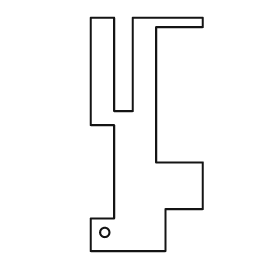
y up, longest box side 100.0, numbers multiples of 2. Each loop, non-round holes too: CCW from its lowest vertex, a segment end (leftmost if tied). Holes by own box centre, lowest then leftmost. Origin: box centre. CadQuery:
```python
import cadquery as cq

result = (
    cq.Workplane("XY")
    .moveTo(-24.0, -50.0)
    .lineTo(8.0, -50.0)
    .lineTo(8.0, -32.0)
    .lineTo(24.0, -32.0)
    .lineTo(24.0, -12.0)
    .lineTo(4.0, -12.0)
    .lineTo(4.0, 46.0)
    .lineTo(24.0, 46.0)
    .lineTo(24.0, 50.0)
    .lineTo(-6.0, 50.0)
    .lineTo(-6.0, 10.0)
    .lineTo(-14.0, 10.0)
    .lineTo(-14.0, 50.0)
    .lineTo(-24.0, 50.0)
    .lineTo(-24.0, 4.0)
    .lineTo(-14.0, 4.0)
    .lineTo(-14.0, -36.0)
    .lineTo(-24.0, -36.0)
    .close()
    .moveTo(-18.0, -42.0)
    .circle(2.0)
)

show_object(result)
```